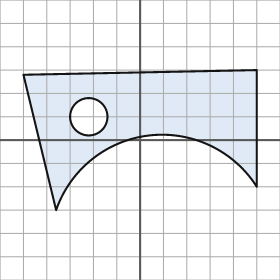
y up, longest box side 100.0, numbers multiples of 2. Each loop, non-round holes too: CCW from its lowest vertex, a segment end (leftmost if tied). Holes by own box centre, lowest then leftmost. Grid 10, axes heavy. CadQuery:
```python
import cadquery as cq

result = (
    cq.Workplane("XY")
    .moveTo(-36.0, -30.0)
    .threePointArc((4.0, 2.0), (50.0, -20.0))
    .lineTo(50.0, 30.0)
    .lineTo(-50.0, 28.0)
    .close()
    .moveTo(-22.0, 10.0)
    .circle(8.0)
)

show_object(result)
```